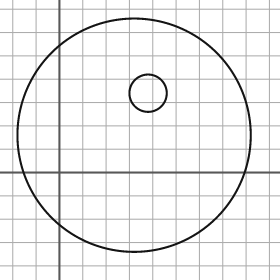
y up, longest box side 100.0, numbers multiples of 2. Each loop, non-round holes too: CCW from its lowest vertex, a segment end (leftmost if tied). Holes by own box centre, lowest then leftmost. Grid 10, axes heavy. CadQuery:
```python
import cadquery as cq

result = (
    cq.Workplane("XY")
    .moveTo(32.0, 16.0)
    .circle(50.0)
    .moveTo(38.0, 34.0)
    .circle(8.0)
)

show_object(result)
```